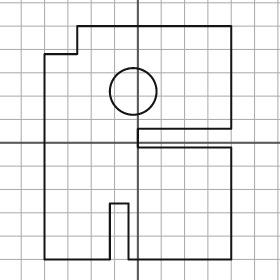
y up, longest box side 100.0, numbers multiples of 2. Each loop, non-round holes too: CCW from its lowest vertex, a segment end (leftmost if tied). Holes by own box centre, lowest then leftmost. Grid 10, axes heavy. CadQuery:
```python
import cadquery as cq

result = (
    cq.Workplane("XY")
    .moveTo(-40.0, -50.0)
    .lineTo(-12.0, -50.0)
    .lineTo(-12.0, -26.0)
    .lineTo(-4.0, -26.0)
    .lineTo(-4.0, -50.0)
    .lineTo(40.0, -50.0)
    .lineTo(40.0, -2.0)
    .lineTo(0.0, -2.0)
    .lineTo(0.0, 6.0)
    .lineTo(40.0, 6.0)
    .lineTo(40.0, 50.0)
    .lineTo(-26.0, 50.0)
    .lineTo(-26.0, 38.0)
    .lineTo(-40.0, 38.0)
    .close()
    .moveTo(-2.0, 22.0)
    .circle(10.0)
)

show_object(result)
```